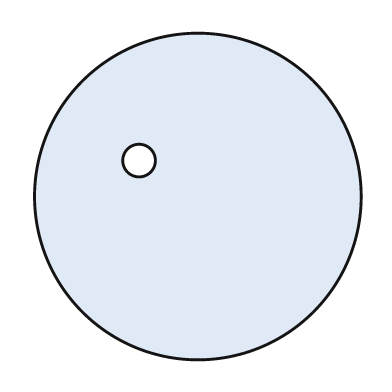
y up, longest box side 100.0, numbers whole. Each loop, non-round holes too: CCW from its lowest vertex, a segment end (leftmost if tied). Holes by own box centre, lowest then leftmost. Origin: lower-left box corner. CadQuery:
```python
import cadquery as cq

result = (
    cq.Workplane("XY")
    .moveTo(50.0, 50.0)
    .circle(50.0)
    .moveTo(32.0, 61.0)
    .circle(5.0)
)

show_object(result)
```